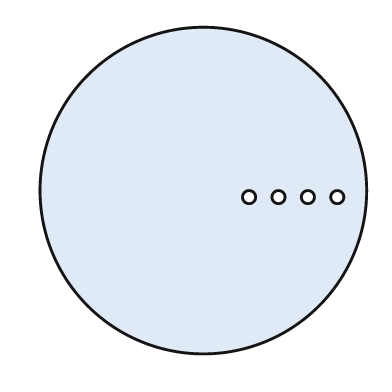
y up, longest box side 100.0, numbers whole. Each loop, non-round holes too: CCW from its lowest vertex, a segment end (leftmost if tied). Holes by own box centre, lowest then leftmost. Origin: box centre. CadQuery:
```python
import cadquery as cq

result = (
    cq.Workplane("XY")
    .moveTo(0.0, 0.0)
    .circle(50.0)
    .moveTo(14.0, -2.0)
    .circle(2.0)
    .moveTo(23.0, -2.0)
    .circle(2.0)
    .moveTo(32.0, -2.0)
    .circle(2.0)
    .moveTo(41.0, -2.0)
    .circle(2.0)
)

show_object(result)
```